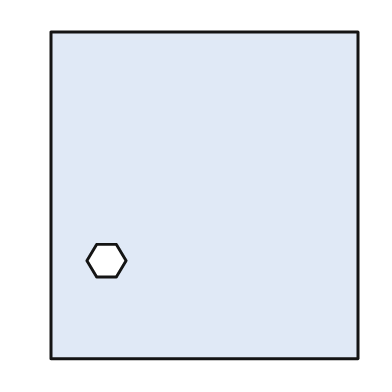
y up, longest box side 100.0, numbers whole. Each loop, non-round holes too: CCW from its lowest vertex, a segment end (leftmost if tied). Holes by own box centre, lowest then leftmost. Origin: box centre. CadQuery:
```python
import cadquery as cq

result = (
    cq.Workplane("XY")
    .moveTo(-47.0, -50.0)
    .lineTo(47.0, -50.0)
    .lineTo(47.0, 50.0)
    .lineTo(-47.0, 50.0)
    .close()
    .moveTo(-33.0, -25.0)
    .lineTo(-27.0, -25.0)
    .lineTo(-24.0, -20.0)
    .lineTo(-27.0, -15.0)
    .lineTo(-33.0, -15.0)
    .lineTo(-36.0, -20.0)
    .close()
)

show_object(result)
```